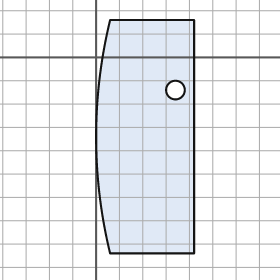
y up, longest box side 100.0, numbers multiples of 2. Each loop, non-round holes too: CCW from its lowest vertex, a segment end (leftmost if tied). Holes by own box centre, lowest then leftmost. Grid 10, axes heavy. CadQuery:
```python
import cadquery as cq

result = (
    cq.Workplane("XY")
    .moveTo(6.0, -84.0)
    .lineTo(42.0, -84.0)
    .lineTo(42.0, 16.0)
    .lineTo(6.0, 16.0)
    .threePointArc((0.0, -34.0), (6.0, -84.0))
    .close()
    .moveTo(34.0, -14.0)
    .circle(4.0)
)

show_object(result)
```